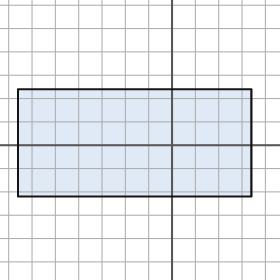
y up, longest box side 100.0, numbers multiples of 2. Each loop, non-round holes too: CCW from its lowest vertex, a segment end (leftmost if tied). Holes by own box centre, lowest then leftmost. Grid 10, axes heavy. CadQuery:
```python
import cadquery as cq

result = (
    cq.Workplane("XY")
    .moveTo(-66.0, -22.0)
    .lineTo(34.0, -22.0)
    .lineTo(34.0, 24.0)
    .lineTo(-66.0, 24.0)
    .close()
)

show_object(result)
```